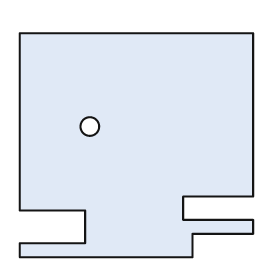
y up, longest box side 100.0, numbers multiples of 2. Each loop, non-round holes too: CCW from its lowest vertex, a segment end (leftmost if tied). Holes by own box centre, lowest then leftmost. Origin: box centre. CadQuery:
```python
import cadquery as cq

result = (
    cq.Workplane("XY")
    .moveTo(-50.0, -48.0)
    .lineTo(24.0, -48.0)
    .lineTo(24.0, -38.0)
    .lineTo(50.0, -38.0)
    .lineTo(50.0, -32.0)
    .lineTo(20.0, -32.0)
    .lineTo(20.0, -22.0)
    .lineTo(50.0, -22.0)
    .lineTo(50.0, 48.0)
    .lineTo(-50.0, 48.0)
    .lineTo(-50.0, -28.0)
    .lineTo(-22.0, -28.0)
    .lineTo(-22.0, -42.0)
    .lineTo(-50.0, -42.0)
    .close()
    .moveTo(-20.0, 8.0)
    .circle(4.0)
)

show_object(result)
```